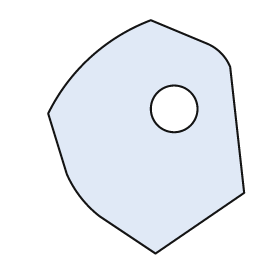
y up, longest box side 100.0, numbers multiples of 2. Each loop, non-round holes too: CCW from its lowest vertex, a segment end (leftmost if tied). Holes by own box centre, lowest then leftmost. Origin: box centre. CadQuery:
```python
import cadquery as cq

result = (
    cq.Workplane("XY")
    .moveTo(4.0, -50.0)
    .lineTo(42.0, -24.0)
    .lineTo(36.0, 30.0)
    .threePointArc((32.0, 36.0), (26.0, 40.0))
    .lineTo(2.0, 50.0)
    .threePointArc((-24.0, 34.0), (-42.0, 10.0))
    .lineTo(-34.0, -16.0)
    .threePointArc((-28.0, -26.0), (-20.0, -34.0))
    .close()
    .moveTo(12.0, 12.0)
    .circle(10.0)
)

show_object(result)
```